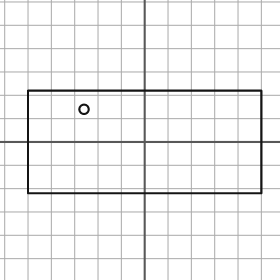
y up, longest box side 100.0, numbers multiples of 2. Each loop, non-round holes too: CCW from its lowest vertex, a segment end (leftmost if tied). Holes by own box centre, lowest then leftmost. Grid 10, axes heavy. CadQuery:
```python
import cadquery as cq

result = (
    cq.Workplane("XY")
    .moveTo(-50.0, -22.0)
    .lineTo(50.0, -22.0)
    .lineTo(50.0, 22.0)
    .lineTo(-50.0, 22.0)
    .close()
    .moveTo(-26.0, 14.0)
    .circle(2.0)
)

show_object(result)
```